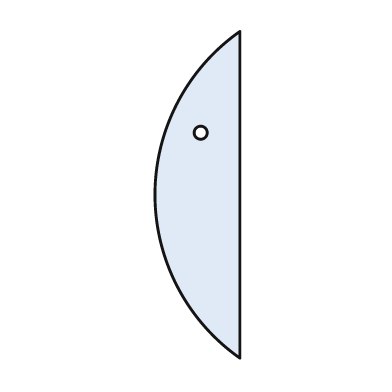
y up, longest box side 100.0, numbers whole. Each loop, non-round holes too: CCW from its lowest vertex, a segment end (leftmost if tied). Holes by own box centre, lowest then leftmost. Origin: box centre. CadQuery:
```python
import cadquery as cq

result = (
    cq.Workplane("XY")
    .moveTo(13.0, -50.0)
    .lineTo(13.0, 50.0)
    .threePointArc((-13.0, 0.0), (13.0, -50.0))
    .close()
    .moveTo(1.0, 19.0)
    .circle(2.0)
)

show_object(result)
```